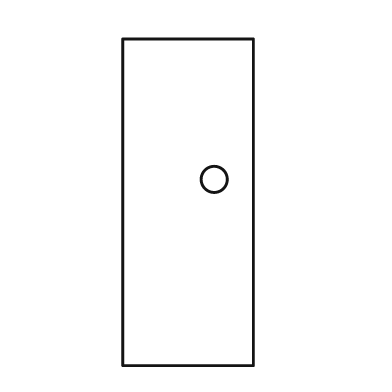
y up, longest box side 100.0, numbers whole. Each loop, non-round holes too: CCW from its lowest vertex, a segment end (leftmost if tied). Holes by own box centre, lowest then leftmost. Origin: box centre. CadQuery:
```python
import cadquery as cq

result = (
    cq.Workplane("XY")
    .moveTo(-20.0, -50.0)
    .lineTo(20.0, -50.0)
    .lineTo(20.0, 50.0)
    .lineTo(-20.0, 50.0)
    .close()
    .moveTo(8.0, 7.0)
    .circle(4.0)
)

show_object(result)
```